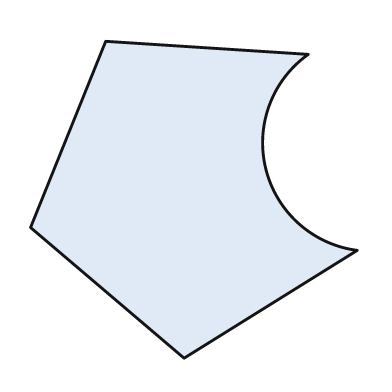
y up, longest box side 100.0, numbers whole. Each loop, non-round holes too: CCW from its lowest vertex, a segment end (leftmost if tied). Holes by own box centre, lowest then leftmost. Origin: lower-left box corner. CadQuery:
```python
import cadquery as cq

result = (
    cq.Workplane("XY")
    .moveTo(47.0, 0.0)
    .lineTo(100.0, 33.0)
    .threePointArc((72.0, 58.0), (85.0, 93.0))
    .lineTo(23.0, 97.0)
    .lineTo(0.0, 40.0)
    .close()
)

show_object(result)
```